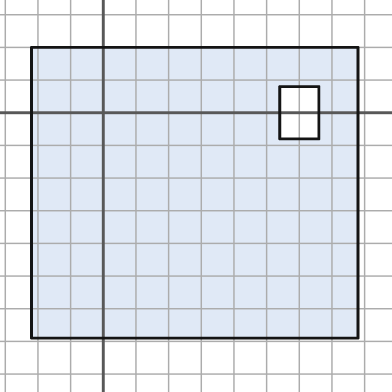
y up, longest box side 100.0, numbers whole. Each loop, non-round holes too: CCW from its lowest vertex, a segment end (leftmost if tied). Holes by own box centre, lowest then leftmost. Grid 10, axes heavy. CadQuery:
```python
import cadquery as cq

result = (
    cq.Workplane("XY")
    .moveTo(-22.0, -69.0)
    .lineTo(78.0, -69.0)
    .lineTo(78.0, 20.0)
    .lineTo(-22.0, 20.0)
    .close()
    .moveTo(54.0, -8.0)
    .lineTo(66.0, -8.0)
    .lineTo(66.0, 8.0)
    .lineTo(54.0, 8.0)
    .close()
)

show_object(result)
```